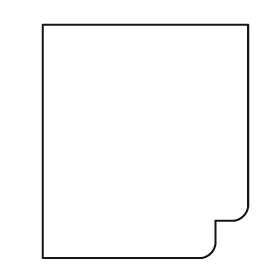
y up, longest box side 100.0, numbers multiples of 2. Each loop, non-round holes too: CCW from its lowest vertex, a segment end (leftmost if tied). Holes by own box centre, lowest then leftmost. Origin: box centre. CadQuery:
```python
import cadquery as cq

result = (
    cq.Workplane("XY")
    .moveTo(-44.0, -50.0)
    .lineTo(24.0, -50.0)
    .threePointArc((28.0, -48.0), (30.0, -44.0))
    .lineTo(30.0, -34.0)
    .lineTo(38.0, -34.0)
    .threePointArc((42.0, -32.0), (44.0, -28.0))
    .lineTo(44.0, 50.0)
    .lineTo(-44.0, 50.0)
    .close()
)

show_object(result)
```